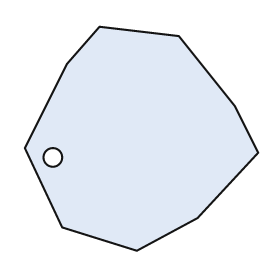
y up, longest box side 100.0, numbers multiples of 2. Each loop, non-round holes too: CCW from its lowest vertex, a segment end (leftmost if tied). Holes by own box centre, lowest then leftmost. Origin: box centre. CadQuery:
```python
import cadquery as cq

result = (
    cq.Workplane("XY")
    .moveTo(-2.0, -48.0)
    .lineTo(24.0, -34.0)
    .lineTo(50.0, -6.0)
    .lineTo(40.0, 14.0)
    .lineTo(16.0, 44.0)
    .lineTo(-18.0, 48.0)
    .lineTo(-32.0, 32.0)
    .lineTo(-50.0, -4.0)
    .lineTo(-34.0, -38.0)
    .close()
    .moveTo(-38.0, -8.0)
    .circle(4.0)
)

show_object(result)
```